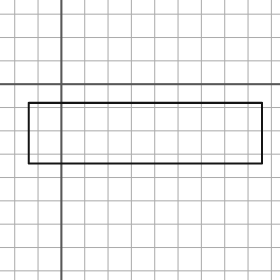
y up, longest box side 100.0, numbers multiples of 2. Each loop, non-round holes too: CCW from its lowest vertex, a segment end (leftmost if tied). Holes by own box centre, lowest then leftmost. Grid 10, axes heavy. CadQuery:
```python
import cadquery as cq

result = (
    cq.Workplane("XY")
    .moveTo(-14.0, -34.0)
    .lineTo(86.0, -34.0)
    .lineTo(86.0, -8.0)
    .lineTo(-14.0, -8.0)
    .close()
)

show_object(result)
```